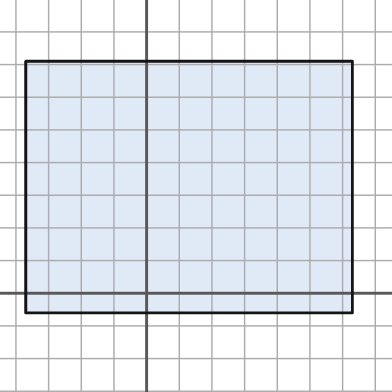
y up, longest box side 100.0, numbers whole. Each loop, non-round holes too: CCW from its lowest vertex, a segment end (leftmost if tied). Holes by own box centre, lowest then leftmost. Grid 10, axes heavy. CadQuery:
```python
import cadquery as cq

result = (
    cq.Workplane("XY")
    .moveTo(-37.0, -6.0)
    .lineTo(63.0, -6.0)
    .lineTo(63.0, 71.0)
    .lineTo(-37.0, 71.0)
    .close()
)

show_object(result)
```